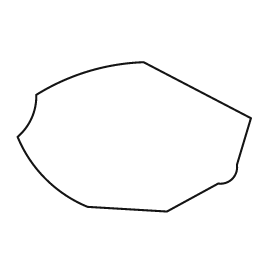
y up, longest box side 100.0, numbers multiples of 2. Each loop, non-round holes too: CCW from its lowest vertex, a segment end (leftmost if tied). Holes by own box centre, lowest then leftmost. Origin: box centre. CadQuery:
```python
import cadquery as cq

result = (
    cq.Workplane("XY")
    .moveTo(14.0, -32.0)
    .lineTo(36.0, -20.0)
    .threePointArc((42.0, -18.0), (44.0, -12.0))
    .lineTo(50.0, 8.0)
    .lineTo(4.0, 32.0)
    .threePointArc((-20.0, 28.0), (-42.0, 18.0))
    .threePointArc((-44.0, 8.0), (-50.0, 0.0))
    .threePointArc((-38.0, -18.0), (-20.0, -30.0))
    .close()
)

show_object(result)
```